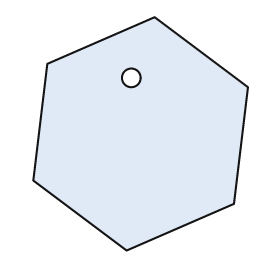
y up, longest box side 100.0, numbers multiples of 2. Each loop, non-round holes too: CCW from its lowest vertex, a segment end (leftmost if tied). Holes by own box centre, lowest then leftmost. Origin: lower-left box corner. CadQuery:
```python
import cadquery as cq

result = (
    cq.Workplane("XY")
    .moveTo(40.0, 0.0)
    .lineTo(86.0, 20.0)
    .lineTo(92.0, 70.0)
    .lineTo(52.0, 100.0)
    .lineTo(6.0, 80.0)
    .lineTo(0.0, 30.0)
    .close()
    .moveTo(42.0, 74.0)
    .circle(4.0)
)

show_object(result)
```